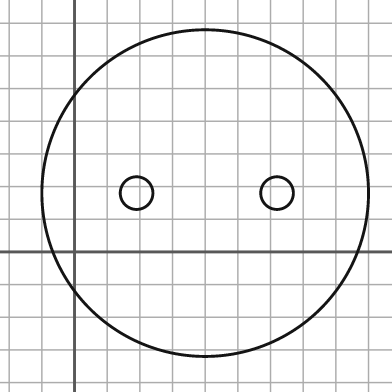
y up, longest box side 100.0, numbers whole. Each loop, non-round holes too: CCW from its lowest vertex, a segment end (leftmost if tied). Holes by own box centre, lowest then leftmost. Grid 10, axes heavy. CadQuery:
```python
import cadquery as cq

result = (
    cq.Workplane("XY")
    .moveTo(40.0, 18.0)
    .circle(50.0)
    .moveTo(19.0, 18.0)
    .circle(5.0)
    .moveTo(62.0, 18.0)
    .circle(5.0)
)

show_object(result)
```